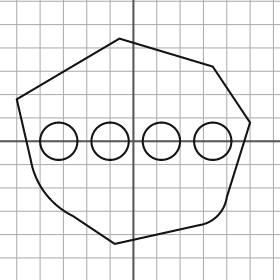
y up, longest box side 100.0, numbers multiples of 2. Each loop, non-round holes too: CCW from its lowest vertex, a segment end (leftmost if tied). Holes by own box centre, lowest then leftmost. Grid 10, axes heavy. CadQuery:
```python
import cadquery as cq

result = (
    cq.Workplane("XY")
    .moveTo(-8.0, -44.0)
    .lineTo(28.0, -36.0)
    .threePointArc((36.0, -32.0), (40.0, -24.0))
    .lineTo(50.0, 8.0)
    .lineTo(34.0, 32.0)
    .lineTo(-6.0, 44.0)
    .lineTo(-50.0, 18.0)
    .lineTo(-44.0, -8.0)
    .threePointArc((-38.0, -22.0), (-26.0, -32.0))
    .close()
    .moveTo(-32.0, 0.0)
    .circle(8.0)
    .moveTo(-10.0, 0.0)
    .circle(8.0)
    .moveTo(12.0, 0.0)
    .circle(8.0)
    .moveTo(34.0, 0.0)
    .circle(8.0)
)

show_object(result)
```